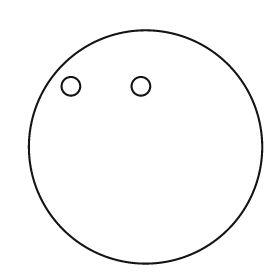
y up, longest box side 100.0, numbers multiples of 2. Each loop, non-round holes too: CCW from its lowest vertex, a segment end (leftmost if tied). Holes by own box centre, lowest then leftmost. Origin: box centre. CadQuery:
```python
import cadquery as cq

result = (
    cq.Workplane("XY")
    .moveTo(0.0, 0.0)
    .circle(50.0)
    .moveTo(-32.0, 26.0)
    .circle(4.0)
    .moveTo(-2.0, 26.0)
    .circle(4.0)
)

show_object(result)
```